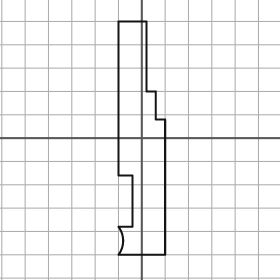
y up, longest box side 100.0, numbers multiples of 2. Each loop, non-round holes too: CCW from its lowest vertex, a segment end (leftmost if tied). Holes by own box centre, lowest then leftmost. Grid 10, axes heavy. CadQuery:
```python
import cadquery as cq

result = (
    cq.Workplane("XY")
    .moveTo(-10.0, -50.0)
    .lineTo(10.0, -50.0)
    .lineTo(10.0, 8.0)
    .lineTo(6.0, 8.0)
    .lineTo(6.0, 20.0)
    .lineTo(2.0, 20.0)
    .lineTo(2.0, 50.0)
    .lineTo(-10.0, 50.0)
    .lineTo(-10.0, -16.0)
    .lineTo(-4.0, -16.0)
    .lineTo(-4.0, -38.0)
    .lineTo(-10.0, -38.0)
    .threePointArc((-8.0, -44.0), (-10.0, -50.0))
    .close()
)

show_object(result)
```